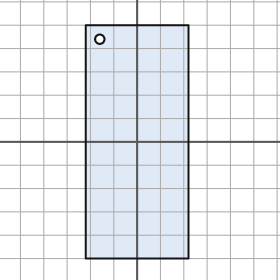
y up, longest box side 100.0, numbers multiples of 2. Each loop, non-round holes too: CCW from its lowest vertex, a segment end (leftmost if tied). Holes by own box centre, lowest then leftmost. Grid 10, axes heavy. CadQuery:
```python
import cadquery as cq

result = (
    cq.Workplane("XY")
    .moveTo(-22.0, -50.0)
    .lineTo(22.0, -50.0)
    .lineTo(22.0, 50.0)
    .lineTo(-22.0, 50.0)
    .close()
    .moveTo(-16.0, 44.0)
    .circle(2.0)
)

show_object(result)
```